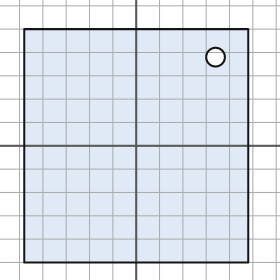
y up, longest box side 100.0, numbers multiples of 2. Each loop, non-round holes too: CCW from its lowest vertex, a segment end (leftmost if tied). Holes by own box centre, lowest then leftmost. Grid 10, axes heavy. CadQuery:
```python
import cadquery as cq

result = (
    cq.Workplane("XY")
    .moveTo(-48.0, -50.0)
    .lineTo(48.0, -50.0)
    .lineTo(48.0, 50.0)
    .lineTo(-48.0, 50.0)
    .close()
    .moveTo(34.0, 38.0)
    .circle(4.0)
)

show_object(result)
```